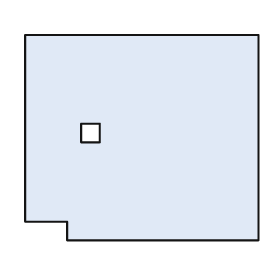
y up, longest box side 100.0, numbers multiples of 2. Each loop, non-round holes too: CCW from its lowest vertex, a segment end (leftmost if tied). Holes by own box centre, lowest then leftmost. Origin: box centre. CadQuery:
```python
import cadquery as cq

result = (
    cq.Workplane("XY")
    .moveTo(-32.0, -44.0)
    .lineTo(50.0, -44.0)
    .lineTo(50.0, 44.0)
    .lineTo(-50.0, 44.0)
    .lineTo(-50.0, -36.0)
    .lineTo(-32.0, -36.0)
    .close()
    .moveTo(-26.0, -2.0)
    .lineTo(-18.0, -2.0)
    .lineTo(-18.0, 6.0)
    .lineTo(-26.0, 6.0)
    .close()
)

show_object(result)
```